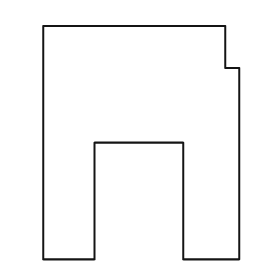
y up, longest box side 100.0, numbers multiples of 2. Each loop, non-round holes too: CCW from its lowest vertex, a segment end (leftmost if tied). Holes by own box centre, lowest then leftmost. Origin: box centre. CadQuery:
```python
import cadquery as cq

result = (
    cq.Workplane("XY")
    .moveTo(-42.0, -50.0)
    .lineTo(-20.0, -50.0)
    .lineTo(-20.0, 0.0)
    .lineTo(18.0, 0.0)
    .lineTo(18.0, -50.0)
    .lineTo(42.0, -50.0)
    .lineTo(42.0, 32.0)
    .lineTo(36.0, 32.0)
    .lineTo(36.0, 50.0)
    .lineTo(-42.0, 50.0)
    .close()
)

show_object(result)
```